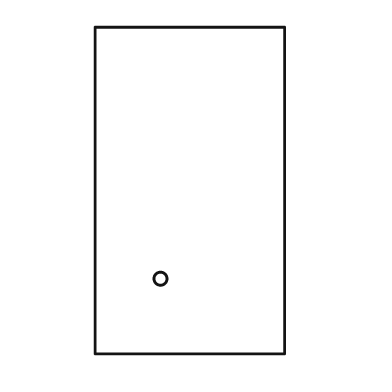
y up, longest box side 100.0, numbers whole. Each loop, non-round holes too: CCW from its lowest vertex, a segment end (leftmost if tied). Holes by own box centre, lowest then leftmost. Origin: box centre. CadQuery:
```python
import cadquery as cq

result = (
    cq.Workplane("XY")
    .moveTo(-29.0, -50.0)
    .lineTo(29.0, -50.0)
    .lineTo(29.0, 50.0)
    .lineTo(-29.0, 50.0)
    .close()
    .moveTo(-9.0, -27.0)
    .circle(2.0)
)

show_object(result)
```